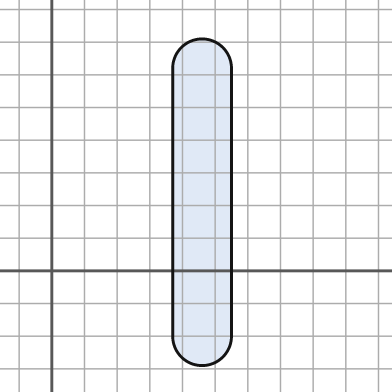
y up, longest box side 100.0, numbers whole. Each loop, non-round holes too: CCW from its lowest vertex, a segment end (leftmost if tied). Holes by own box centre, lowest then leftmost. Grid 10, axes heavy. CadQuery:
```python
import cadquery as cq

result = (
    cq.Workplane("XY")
    .moveTo(37.0, -20.0)
    .threePointArc((46.0, -29.0), (55.0, -20.0))
    .lineTo(55.0, 62.0)
    .threePointArc((46.0, 71.0), (37.0, 62.0))
    .close()
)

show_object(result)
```